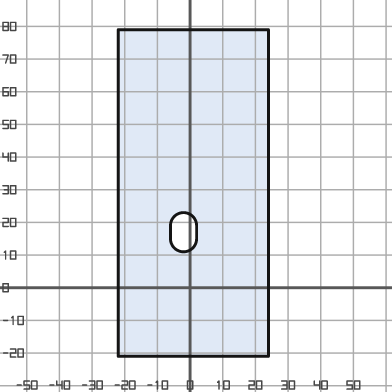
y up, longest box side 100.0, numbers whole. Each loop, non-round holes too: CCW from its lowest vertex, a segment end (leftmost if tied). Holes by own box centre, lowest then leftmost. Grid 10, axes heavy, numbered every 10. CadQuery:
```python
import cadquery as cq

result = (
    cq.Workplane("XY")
    .moveTo(-22.0, -21.0)
    .lineTo(24.0, -21.0)
    .lineTo(24.0, 79.0)
    .lineTo(-22.0, 79.0)
    .close()
    .moveTo(-6.0, 15.0)
    .threePointArc((-2.0, 11.0), (2.0, 15.0))
    .lineTo(2.0, 19.0)
    .threePointArc((-2.0, 23.0), (-6.0, 19.0))
    .close()
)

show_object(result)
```